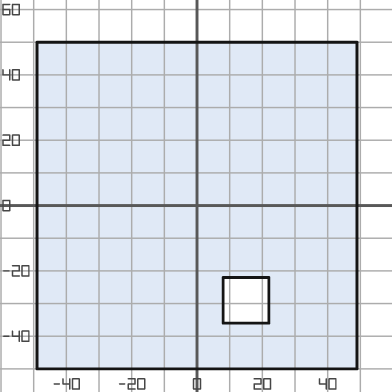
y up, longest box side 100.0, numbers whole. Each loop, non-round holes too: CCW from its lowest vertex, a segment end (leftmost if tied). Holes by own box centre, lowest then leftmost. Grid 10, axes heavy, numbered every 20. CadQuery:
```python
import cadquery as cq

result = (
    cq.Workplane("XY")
    .moveTo(-49.0, -50.0)
    .lineTo(49.0, -50.0)
    .lineTo(49.0, 50.0)
    .lineTo(-49.0, 50.0)
    .close()
    .moveTo(8.0, -36.0)
    .lineTo(22.0, -36.0)
    .lineTo(22.0, -22.0)
    .lineTo(8.0, -22.0)
    .close()
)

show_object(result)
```